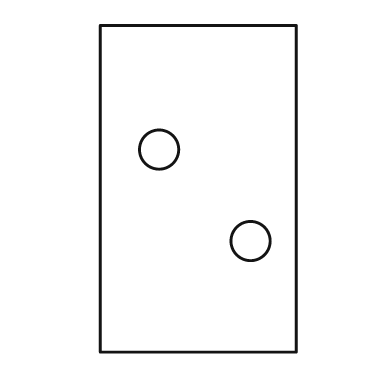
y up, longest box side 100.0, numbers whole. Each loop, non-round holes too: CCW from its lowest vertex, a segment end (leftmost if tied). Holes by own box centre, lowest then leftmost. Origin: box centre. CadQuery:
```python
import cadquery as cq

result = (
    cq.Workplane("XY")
    .moveTo(-30.0, -50.0)
    .lineTo(30.0, -50.0)
    .lineTo(30.0, 50.0)
    .lineTo(-30.0, 50.0)
    .close()
    .moveTo(16.0, -16.0)
    .circle(6.0)
    .moveTo(-12.0, 12.0)
    .circle(6.0)
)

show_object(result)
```